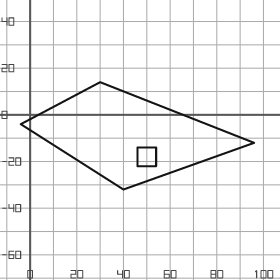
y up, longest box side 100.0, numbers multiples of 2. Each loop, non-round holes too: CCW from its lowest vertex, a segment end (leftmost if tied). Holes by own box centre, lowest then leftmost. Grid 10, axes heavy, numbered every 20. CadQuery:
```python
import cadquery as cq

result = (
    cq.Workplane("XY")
    .moveTo(40.0, -32.0)
    .lineTo(96.0, -12.0)
    .lineTo(30.0, 14.0)
    .lineTo(-4.0, -4.0)
    .close()
    .moveTo(46.0, -22.0)
    .lineTo(54.0, -22.0)
    .lineTo(54.0, -14.0)
    .lineTo(46.0, -14.0)
    .close()
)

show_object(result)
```